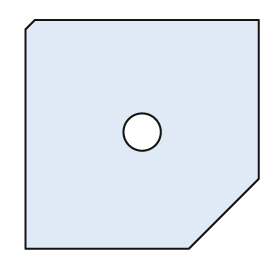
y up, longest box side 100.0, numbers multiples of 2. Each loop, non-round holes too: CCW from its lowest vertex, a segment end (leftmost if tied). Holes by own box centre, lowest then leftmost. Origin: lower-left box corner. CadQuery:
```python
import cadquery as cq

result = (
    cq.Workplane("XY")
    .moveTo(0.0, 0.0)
    .lineTo(70.0, 0.0)
    .lineTo(100.0, 30.0)
    .lineTo(100.0, 98.0)
    .lineTo(4.0, 98.0)
    .lineTo(0.0, 94.0)
    .close()
    .moveTo(50.0, 50.0)
    .circle(8.0)
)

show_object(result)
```